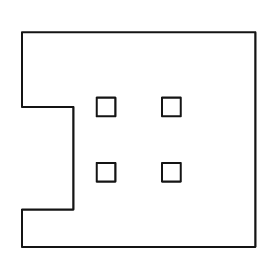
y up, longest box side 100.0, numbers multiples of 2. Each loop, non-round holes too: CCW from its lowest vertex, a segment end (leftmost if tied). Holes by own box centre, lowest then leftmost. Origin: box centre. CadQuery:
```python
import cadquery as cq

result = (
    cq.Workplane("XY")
    .moveTo(-50.0, -46.0)
    .lineTo(50.0, -46.0)
    .lineTo(50.0, 46.0)
    .lineTo(-50.0, 46.0)
    .lineTo(-50.0, 14.0)
    .lineTo(-28.0, 14.0)
    .lineTo(-28.0, -30.0)
    .lineTo(-50.0, -30.0)
    .close()
    .moveTo(-18.0, -18.0)
    .lineTo(-10.0, -18.0)
    .lineTo(-10.0, -10.0)
    .lineTo(-18.0, -10.0)
    .close()
    .moveTo(10.0, -18.0)
    .lineTo(18.0, -18.0)
    .lineTo(18.0, -10.0)
    .lineTo(10.0, -10.0)
    .close()
    .moveTo(-18.0, 10.0)
    .lineTo(-10.0, 10.0)
    .lineTo(-10.0, 18.0)
    .lineTo(-18.0, 18.0)
    .close()
    .moveTo(10.0, 10.0)
    .lineTo(18.0, 10.0)
    .lineTo(18.0, 18.0)
    .lineTo(10.0, 18.0)
    .close()
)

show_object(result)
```